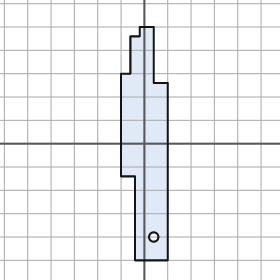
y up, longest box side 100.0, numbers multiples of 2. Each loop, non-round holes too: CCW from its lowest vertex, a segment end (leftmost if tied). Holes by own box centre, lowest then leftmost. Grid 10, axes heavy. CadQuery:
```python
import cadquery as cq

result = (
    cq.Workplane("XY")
    .moveTo(-4.0, -50.0)
    .lineTo(10.0, -50.0)
    .lineTo(10.0, 26.0)
    .lineTo(4.0, 26.0)
    .lineTo(4.0, 50.0)
    .lineTo(-2.0, 50.0)
    .lineTo(-2.0, 46.0)
    .lineTo(-6.0, 46.0)
    .lineTo(-6.0, 30.0)
    .lineTo(-10.0, 30.0)
    .lineTo(-10.0, -14.0)
    .lineTo(-4.0, -14.0)
    .close()
    .moveTo(4.0, -40.0)
    .circle(2.0)
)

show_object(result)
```